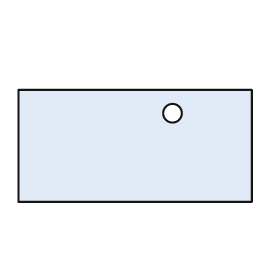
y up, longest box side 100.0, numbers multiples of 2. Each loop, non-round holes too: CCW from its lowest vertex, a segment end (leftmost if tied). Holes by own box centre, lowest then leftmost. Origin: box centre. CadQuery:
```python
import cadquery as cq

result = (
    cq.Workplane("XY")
    .moveTo(-50.0, -24.0)
    .lineTo(50.0, -24.0)
    .lineTo(50.0, 24.0)
    .lineTo(-50.0, 24.0)
    .close()
    .moveTo(16.0, 14.0)
    .circle(4.0)
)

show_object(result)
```